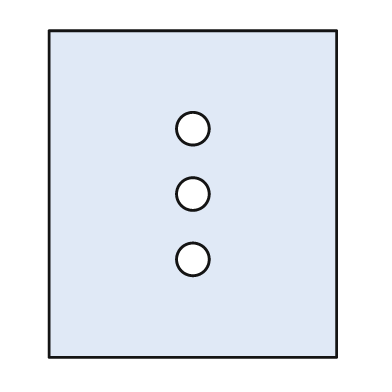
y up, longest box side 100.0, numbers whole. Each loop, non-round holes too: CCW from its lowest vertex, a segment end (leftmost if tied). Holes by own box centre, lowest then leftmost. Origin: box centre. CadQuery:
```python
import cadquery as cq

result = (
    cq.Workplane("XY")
    .moveTo(-44.0, -50.0)
    .lineTo(44.0, -50.0)
    .lineTo(44.0, 50.0)
    .lineTo(-44.0, 50.0)
    .close()
    .moveTo(0.0, -20.0)
    .circle(5.0)
    .moveTo(0.0, 0.0)
    .circle(5.0)
    .moveTo(0.0, 20.0)
    .circle(5.0)
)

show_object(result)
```